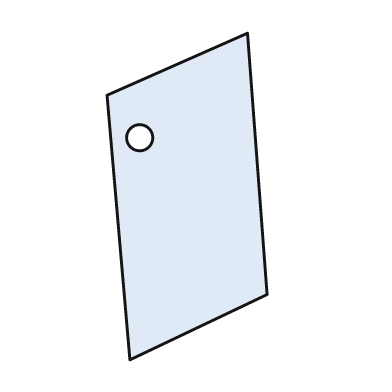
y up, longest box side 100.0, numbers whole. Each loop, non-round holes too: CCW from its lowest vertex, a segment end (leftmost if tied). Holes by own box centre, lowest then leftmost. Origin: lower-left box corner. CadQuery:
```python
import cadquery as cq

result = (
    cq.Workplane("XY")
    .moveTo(7.0, 0.0)
    .lineTo(49.0, 20.0)
    .lineTo(43.0, 100.0)
    .lineTo(0.0, 81.0)
    .close()
    .moveTo(10.0, 68.0)
    .circle(4.0)
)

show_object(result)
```